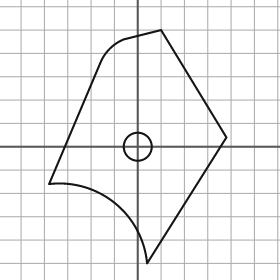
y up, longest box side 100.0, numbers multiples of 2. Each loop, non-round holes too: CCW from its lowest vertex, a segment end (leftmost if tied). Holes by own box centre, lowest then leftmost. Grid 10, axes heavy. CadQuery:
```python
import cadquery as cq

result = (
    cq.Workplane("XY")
    .moveTo(4.0, -50.0)
    .lineTo(38.0, 4.0)
    .lineTo(10.0, 50.0)
    .lineTo(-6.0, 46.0)
    .threePointArc((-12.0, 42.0), (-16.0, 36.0))
    .lineTo(-38.0, -16.0)
    .threePointArc((-10.0, -24.0), (4.0, -50.0))
    .close()
    .moveTo(0.0, 0.0)
    .circle(6.0)
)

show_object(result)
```